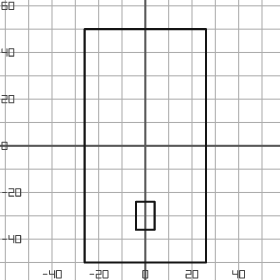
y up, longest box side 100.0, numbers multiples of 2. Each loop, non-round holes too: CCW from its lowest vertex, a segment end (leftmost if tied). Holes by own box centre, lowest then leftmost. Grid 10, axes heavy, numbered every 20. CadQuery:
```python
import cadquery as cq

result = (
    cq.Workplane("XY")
    .moveTo(-26.0, -50.0)
    .lineTo(26.0, -50.0)
    .lineTo(26.0, 50.0)
    .lineTo(-26.0, 50.0)
    .close()
    .moveTo(-4.0, -36.0)
    .lineTo(4.0, -36.0)
    .lineTo(4.0, -24.0)
    .lineTo(-4.0, -24.0)
    .close()
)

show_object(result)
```